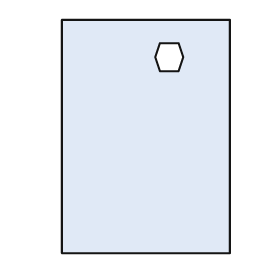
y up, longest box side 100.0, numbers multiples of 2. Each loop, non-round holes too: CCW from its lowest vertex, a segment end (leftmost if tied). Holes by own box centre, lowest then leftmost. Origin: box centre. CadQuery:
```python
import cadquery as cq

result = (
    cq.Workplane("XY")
    .moveTo(-36.0, -50.0)
    .lineTo(36.0, -50.0)
    .lineTo(36.0, 50.0)
    .lineTo(-36.0, 50.0)
    .close()
    .moveTo(6.0, 28.0)
    .lineTo(14.0, 28.0)
    .lineTo(16.0, 34.0)
    .lineTo(14.0, 40.0)
    .lineTo(6.0, 40.0)
    .lineTo(4.0, 34.0)
    .close()
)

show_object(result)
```